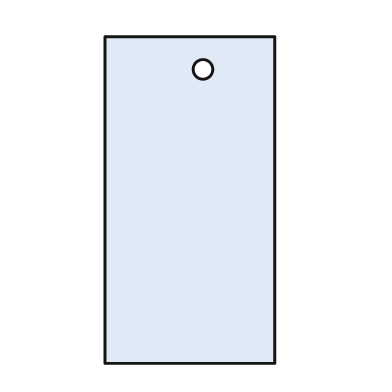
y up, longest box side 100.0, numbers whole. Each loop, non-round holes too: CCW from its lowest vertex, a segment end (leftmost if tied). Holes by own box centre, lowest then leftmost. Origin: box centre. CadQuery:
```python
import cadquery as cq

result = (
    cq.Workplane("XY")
    .moveTo(-26.0, -50.0)
    .lineTo(26.0, -50.0)
    .lineTo(26.0, 50.0)
    .lineTo(-26.0, 50.0)
    .close()
    .moveTo(4.0, 40.0)
    .circle(3.0)
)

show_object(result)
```